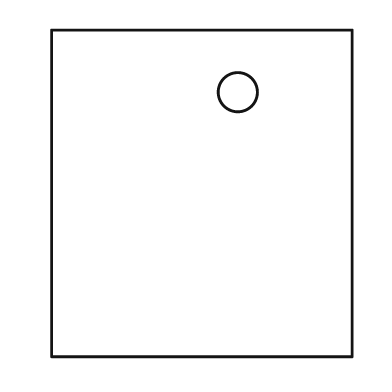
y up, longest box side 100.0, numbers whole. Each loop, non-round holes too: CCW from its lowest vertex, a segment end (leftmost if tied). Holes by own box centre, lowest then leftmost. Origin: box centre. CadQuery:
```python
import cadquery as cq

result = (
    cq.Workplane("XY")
    .moveTo(-46.0, -50.0)
    .lineTo(46.0, -50.0)
    .lineTo(46.0, 50.0)
    .lineTo(-46.0, 50.0)
    .close()
    .moveTo(11.0, 31.0)
    .circle(6.0)
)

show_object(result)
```